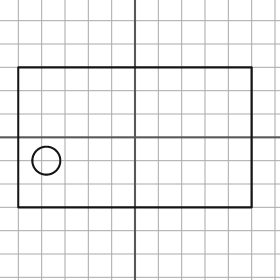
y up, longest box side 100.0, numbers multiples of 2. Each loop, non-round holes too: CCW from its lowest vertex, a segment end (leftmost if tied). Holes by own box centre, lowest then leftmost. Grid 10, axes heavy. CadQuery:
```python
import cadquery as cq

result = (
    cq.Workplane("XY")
    .moveTo(-50.0, -30.0)
    .lineTo(50.0, -30.0)
    .lineTo(50.0, 30.0)
    .lineTo(-50.0, 30.0)
    .close()
    .moveTo(-38.0, -10.0)
    .circle(6.0)
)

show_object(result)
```